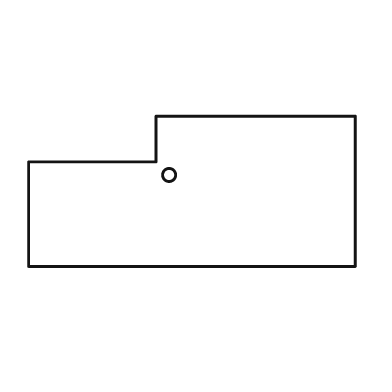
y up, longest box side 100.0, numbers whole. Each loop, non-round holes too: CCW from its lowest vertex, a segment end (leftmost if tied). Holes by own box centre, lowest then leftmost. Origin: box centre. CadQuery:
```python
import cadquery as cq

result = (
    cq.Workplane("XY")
    .moveTo(-50.0, -23.0)
    .lineTo(50.0, -23.0)
    .lineTo(50.0, 23.0)
    .lineTo(-11.0, 23.0)
    .lineTo(-11.0, 9.0)
    .lineTo(-50.0, 9.0)
    .close()
    .moveTo(-7.0, 5.0)
    .circle(2.0)
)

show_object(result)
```